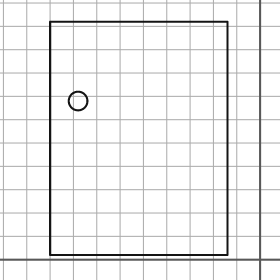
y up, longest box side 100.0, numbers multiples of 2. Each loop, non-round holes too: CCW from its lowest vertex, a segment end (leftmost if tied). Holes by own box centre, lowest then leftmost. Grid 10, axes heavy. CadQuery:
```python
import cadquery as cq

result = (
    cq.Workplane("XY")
    .moveTo(-90.0, 2.0)
    .lineTo(-14.0, 2.0)
    .lineTo(-14.0, 102.0)
    .lineTo(-90.0, 102.0)
    .close()
    .moveTo(-78.0, 68.0)
    .circle(4.0)
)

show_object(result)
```